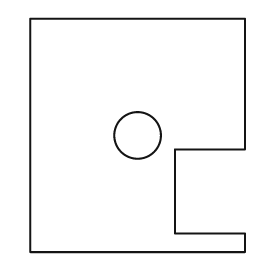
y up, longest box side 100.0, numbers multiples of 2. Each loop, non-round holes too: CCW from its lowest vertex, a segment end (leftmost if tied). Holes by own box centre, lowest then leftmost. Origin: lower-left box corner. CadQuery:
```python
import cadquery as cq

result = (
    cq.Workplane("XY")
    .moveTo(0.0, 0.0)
    .lineTo(92.0, 0.0)
    .lineTo(92.0, 8.0)
    .lineTo(62.0, 8.0)
    .lineTo(62.0, 44.0)
    .lineTo(92.0, 44.0)
    .lineTo(92.0, 100.0)
    .lineTo(0.0, 100.0)
    .close()
    .moveTo(46.0, 50.0)
    .circle(10.0)
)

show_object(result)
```